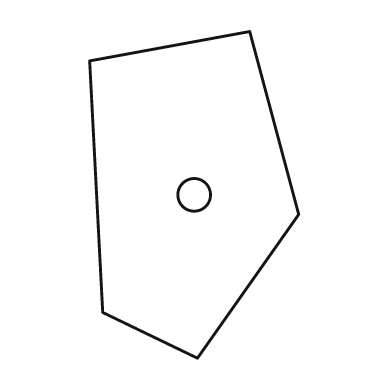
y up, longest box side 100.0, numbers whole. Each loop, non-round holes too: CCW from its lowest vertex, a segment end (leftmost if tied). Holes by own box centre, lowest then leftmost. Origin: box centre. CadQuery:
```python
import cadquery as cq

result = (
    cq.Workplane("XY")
    .moveTo(1.0, -50.0)
    .lineTo(32.0, -6.0)
    .lineTo(17.0, 50.0)
    .lineTo(-32.0, 41.0)
    .lineTo(-28.0, -36.0)
    .close()
    .moveTo(0.0, 0.0)
    .circle(5.0)
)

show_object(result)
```